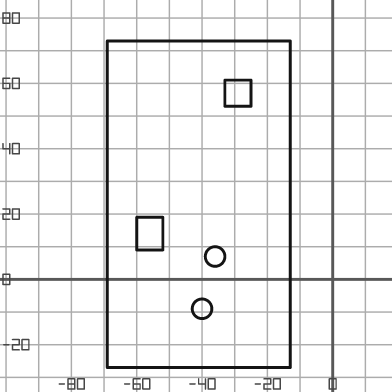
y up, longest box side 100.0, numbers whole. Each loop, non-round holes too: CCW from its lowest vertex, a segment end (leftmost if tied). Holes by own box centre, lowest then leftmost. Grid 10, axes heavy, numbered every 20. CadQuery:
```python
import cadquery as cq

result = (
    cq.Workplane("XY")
    .moveTo(-69.0, -27.0)
    .lineTo(-13.0, -27.0)
    .lineTo(-13.0, 73.0)
    .lineTo(-69.0, 73.0)
    .close()
    .moveTo(-40.0, -9.0)
    .circle(3.0)
    .moveTo(-36.0, 7.0)
    .circle(3.0)
    .moveTo(-60.0, 9.0)
    .lineTo(-52.0, 9.0)
    .lineTo(-52.0, 19.0)
    .lineTo(-60.0, 19.0)
    .close()
    .moveTo(-33.0, 53.0)
    .lineTo(-25.0, 53.0)
    .lineTo(-25.0, 61.0)
    .lineTo(-33.0, 61.0)
    .close()
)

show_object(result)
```